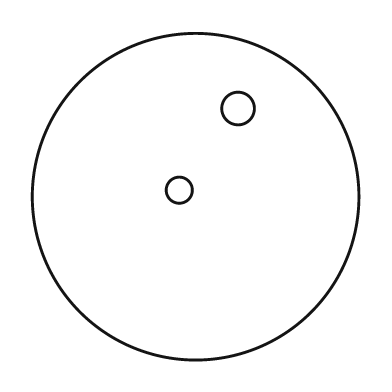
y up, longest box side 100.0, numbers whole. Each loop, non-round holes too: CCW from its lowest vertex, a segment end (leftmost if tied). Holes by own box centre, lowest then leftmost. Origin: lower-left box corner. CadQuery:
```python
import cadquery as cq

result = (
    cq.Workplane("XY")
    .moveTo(50.0, 50.0)
    .circle(50.0)
    .moveTo(45.0, 52.0)
    .circle(4.0)
    .moveTo(63.0, 77.0)
    .circle(5.0)
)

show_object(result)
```